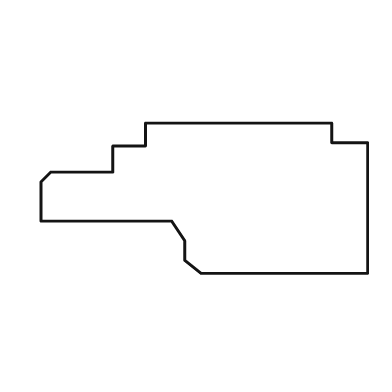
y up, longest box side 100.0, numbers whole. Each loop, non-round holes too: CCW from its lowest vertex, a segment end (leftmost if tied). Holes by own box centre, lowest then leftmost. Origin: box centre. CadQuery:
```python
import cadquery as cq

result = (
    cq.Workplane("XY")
    .moveTo(-1.0, -23.0)
    .lineTo(50.0, -23.0)
    .lineTo(50.0, 17.0)
    .lineTo(39.0, 17.0)
    .lineTo(39.0, 23.0)
    .lineTo(-18.0, 23.0)
    .lineTo(-18.0, 16.0)
    .lineTo(-28.0, 16.0)
    .lineTo(-28.0, 8.0)
    .lineTo(-47.0, 8.0)
    .lineTo(-50.0, 5.0)
    .lineTo(-50.0, -7.0)
    .lineTo(-10.0, -7.0)
    .lineTo(-6.0, -13.0)
    .lineTo(-6.0, -19.0)
    .close()
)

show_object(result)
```